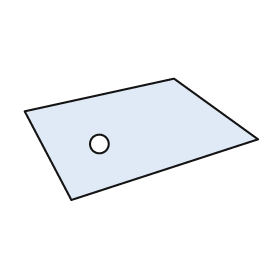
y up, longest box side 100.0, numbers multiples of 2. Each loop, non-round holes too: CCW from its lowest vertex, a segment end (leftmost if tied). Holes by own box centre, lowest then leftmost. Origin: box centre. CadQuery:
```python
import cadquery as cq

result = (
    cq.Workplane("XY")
    .moveTo(-30.0, -26.0)
    .lineTo(50.0, 0.0)
    .lineTo(14.0, 26.0)
    .lineTo(-50.0, 12.0)
    .close()
    .moveTo(-18.0, -2.0)
    .circle(4.0)
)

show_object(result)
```